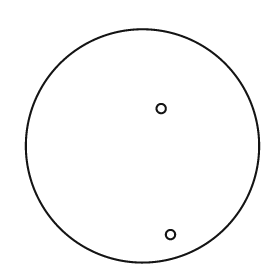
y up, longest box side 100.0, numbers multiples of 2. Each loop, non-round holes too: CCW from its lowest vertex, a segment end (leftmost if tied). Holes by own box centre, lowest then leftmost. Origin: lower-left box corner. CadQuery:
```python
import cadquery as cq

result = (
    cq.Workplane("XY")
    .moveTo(50.0, 50.0)
    .circle(50.0)
    .moveTo(62.0, 12.0)
    .circle(2.0)
    .moveTo(58.0, 66.0)
    .circle(2.0)
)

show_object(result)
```